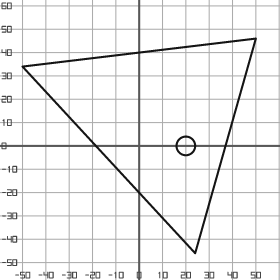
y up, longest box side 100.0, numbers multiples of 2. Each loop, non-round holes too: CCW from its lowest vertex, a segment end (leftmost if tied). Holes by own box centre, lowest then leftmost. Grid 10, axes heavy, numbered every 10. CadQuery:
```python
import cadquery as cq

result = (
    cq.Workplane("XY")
    .moveTo(24.0, -46.0)
    .lineTo(50.0, 46.0)
    .lineTo(-50.0, 34.0)
    .close()
    .moveTo(20.0, 0.0)
    .circle(4.0)
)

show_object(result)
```